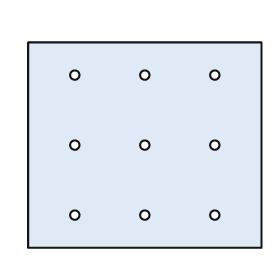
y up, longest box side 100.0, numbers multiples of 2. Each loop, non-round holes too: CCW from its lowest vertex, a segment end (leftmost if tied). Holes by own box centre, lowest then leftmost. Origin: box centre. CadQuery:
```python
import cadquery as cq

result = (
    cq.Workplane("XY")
    .moveTo(-50.0, -44.0)
    .lineTo(50.0, -44.0)
    .lineTo(50.0, 44.0)
    .lineTo(-50.0, 44.0)
    .close()
    .moveTo(-30.0, -30.0)
    .circle(2.0)
    .moveTo(0.0, -30.0)
    .circle(2.0)
    .moveTo(30.0, -30.0)
    .circle(2.0)
    .moveTo(-30.0, 0.0)
    .circle(2.0)
    .moveTo(0.0, 0.0)
    .circle(2.0)
    .moveTo(30.0, 0.0)
    .circle(2.0)
    .moveTo(-30.0, 30.0)
    .circle(2.0)
    .moveTo(0.0, 30.0)
    .circle(2.0)
    .moveTo(30.0, 30.0)
    .circle(2.0)
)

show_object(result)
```